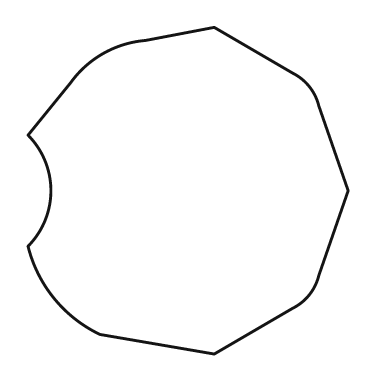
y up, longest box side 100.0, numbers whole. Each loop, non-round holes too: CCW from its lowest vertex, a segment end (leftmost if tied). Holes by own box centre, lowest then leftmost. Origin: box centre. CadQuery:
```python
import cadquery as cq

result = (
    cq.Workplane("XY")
    .moveTo(8.0, -50.0)
    .lineTo(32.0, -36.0)
    .threePointArc((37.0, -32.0), (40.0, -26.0))
    .lineTo(49.0, 0.0)
    .lineTo(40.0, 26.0)
    .threePointArc((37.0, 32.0), (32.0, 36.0))
    .lineTo(8.0, 50.0)
    .lineTo(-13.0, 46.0)
    .threePointArc((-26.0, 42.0), (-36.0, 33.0))
    .lineTo(-49.0, 17.0)
    .threePointArc((-42.0, 0.0), (-49.0, -17.0))
    .threePointArc((-41.0, -33.0), (-27.0, -44.0))
    .close()
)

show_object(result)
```